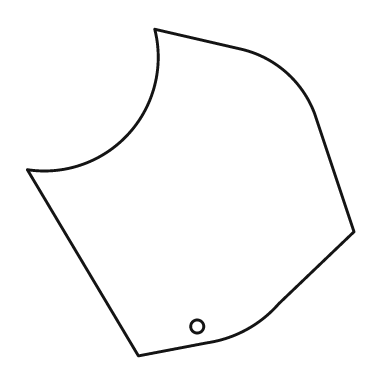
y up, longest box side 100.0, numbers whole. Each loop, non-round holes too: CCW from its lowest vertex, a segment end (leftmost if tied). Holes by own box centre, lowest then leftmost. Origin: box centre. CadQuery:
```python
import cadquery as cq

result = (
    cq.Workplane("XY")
    .moveTo(-16.0, -50.0)
    .lineTo(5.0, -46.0)
    .threePointArc((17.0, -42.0), (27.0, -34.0))
    .lineTo(50.0, -12.0)
    .lineTo(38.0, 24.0)
    .threePointArc((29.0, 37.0), (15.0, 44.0))
    .lineTo(-11.0, 50.0)
    .threePointArc((-19.0, 18.0), (-50.0, 7.0))
    .close()
    .moveTo(2.0, -41.0)
    .circle(2.0)
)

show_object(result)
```